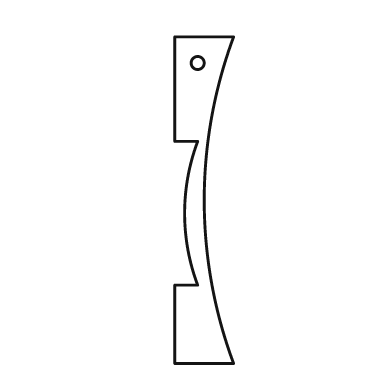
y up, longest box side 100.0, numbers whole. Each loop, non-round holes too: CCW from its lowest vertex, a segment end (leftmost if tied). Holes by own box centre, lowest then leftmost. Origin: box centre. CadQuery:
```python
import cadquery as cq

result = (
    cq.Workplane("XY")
    .moveTo(-9.0, -50.0)
    .lineTo(9.0, -50.0)
    .threePointArc((0.0, 0.0), (9.0, 50.0))
    .lineTo(-9.0, 50.0)
    .lineTo(-9.0, 18.0)
    .lineTo(-2.0, 18.0)
    .threePointArc((-6.0, -4.0), (-2.0, -26.0))
    .lineTo(-9.0, -26.0)
    .close()
    .moveTo(-2.0, 42.0)
    .circle(2.0)
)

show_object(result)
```